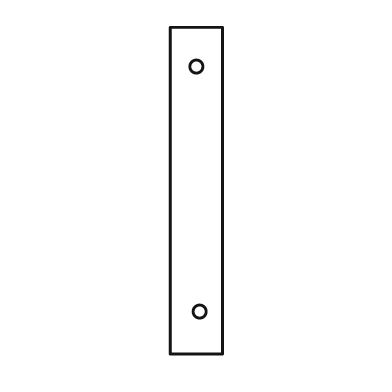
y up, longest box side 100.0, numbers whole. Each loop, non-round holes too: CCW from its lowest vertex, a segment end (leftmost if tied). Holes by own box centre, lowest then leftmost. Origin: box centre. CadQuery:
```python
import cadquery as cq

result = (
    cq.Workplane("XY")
    .moveTo(-8.0, -50.0)
    .lineTo(8.0, -50.0)
    .lineTo(8.0, 50.0)
    .lineTo(-8.0, 50.0)
    .close()
    .moveTo(1.0, -37.0)
    .circle(2.0)
    .moveTo(0.0, 38.0)
    .circle(2.0)
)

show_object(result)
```